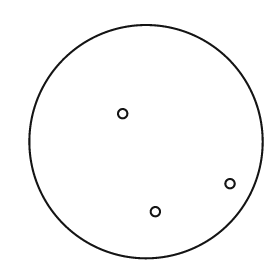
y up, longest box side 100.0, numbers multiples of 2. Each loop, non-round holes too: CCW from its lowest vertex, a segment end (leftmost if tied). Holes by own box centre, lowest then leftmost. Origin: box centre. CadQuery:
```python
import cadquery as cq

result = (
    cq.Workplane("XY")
    .moveTo(0.0, 0.0)
    .circle(50.0)
    .moveTo(4.0, -30.0)
    .circle(2.0)
    .moveTo(36.0, -18.0)
    .circle(2.0)
    .moveTo(-10.0, 12.0)
    .circle(2.0)
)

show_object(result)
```